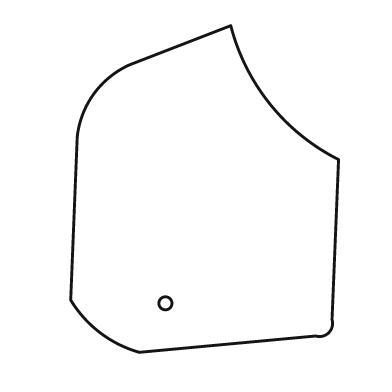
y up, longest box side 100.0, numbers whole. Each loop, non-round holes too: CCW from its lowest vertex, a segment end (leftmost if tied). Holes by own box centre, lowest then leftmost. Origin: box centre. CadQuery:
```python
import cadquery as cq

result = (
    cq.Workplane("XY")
    .moveTo(-20.0, -50.0)
    .lineTo(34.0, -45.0)
    .threePointArc((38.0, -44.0), (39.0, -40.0))
    .lineTo(41.0, 9.0)
    .threePointArc((20.0, 26.0), (8.0, 50.0))
    .lineTo(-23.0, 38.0)
    .threePointArc((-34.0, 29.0), (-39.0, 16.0))
    .lineTo(-41.0, -34.0)
    .threePointArc((-32.0, -44.0), (-20.0, -50.0))
    .close()
    .moveTo(-12.0, -35.0)
    .circle(2.0)
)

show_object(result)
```